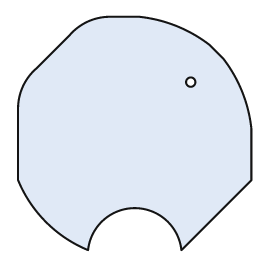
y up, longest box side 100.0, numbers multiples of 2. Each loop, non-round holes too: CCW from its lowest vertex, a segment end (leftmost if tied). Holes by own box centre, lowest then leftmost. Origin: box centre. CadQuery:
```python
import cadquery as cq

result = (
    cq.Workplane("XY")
    .moveTo(-20.0, -50.0)
    .threePointArc((0.0, -32.0), (20.0, -50.0))
    .lineTo(50.0, -20.0)
    .lineTo(50.0, 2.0)
    .threePointArc((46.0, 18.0), (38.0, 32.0))
    .lineTo(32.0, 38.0)
    .threePointArc((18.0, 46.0), (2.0, 50.0))
    .lineTo(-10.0, 50.0)
    .threePointArc((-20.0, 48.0), (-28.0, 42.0))
    .lineTo(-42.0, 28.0)
    .threePointArc((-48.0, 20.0), (-50.0, 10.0))
    .lineTo(-50.0, -20.0)
    .threePointArc((-38.0, -38.0), (-20.0, -50.0))
    .close()
    .moveTo(24.0, 22.0)
    .circle(2.0)
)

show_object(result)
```